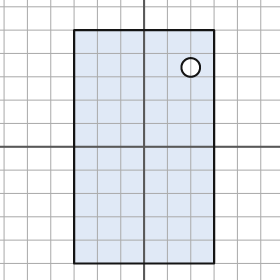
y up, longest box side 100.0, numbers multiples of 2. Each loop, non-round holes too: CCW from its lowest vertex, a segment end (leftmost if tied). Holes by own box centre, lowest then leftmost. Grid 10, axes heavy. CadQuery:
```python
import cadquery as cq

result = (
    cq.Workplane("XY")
    .moveTo(-30.0, -50.0)
    .lineTo(30.0, -50.0)
    .lineTo(30.0, 50.0)
    .lineTo(-30.0, 50.0)
    .close()
    .moveTo(20.0, 34.0)
    .circle(4.0)
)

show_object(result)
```